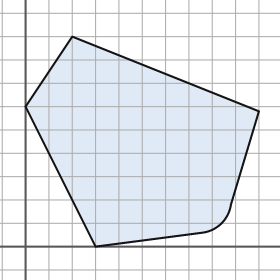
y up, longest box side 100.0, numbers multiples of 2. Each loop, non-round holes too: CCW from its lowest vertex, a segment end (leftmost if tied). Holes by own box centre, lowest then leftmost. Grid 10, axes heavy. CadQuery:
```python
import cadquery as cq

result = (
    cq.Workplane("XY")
    .moveTo(30.0, 0.0)
    .lineTo(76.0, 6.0)
    .threePointArc((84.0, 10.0), (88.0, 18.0))
    .lineTo(100.0, 58.0)
    .lineTo(20.0, 90.0)
    .lineTo(0.0, 60.0)
    .close()
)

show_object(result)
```